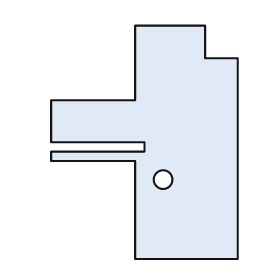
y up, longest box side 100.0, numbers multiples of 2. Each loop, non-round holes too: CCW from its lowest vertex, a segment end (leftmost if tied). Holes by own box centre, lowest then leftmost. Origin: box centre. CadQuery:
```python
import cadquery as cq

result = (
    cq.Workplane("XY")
    .moveTo(-4.0, -50.0)
    .lineTo(40.0, -50.0)
    .lineTo(40.0, 36.0)
    .lineTo(26.0, 36.0)
    .lineTo(26.0, 50.0)
    .lineTo(-4.0, 50.0)
    .lineTo(-4.0, 18.0)
    .lineTo(-40.0, 18.0)
    .lineTo(-40.0, 0.0)
    .lineTo(0.0, 0.0)
    .lineTo(0.0, -4.0)
    .lineTo(-40.0, -4.0)
    .lineTo(-40.0, -8.0)
    .lineTo(-4.0, -8.0)
    .close()
    .moveTo(8.0, -16.0)
    .circle(4.0)
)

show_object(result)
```